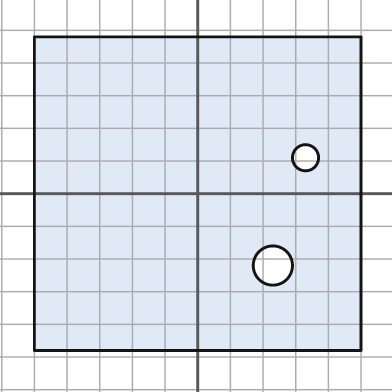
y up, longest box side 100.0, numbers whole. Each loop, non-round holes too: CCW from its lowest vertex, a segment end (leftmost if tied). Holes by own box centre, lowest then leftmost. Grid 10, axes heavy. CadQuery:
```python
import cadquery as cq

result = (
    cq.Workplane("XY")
    .moveTo(-50.0, -48.0)
    .lineTo(50.0, -48.0)
    .lineTo(50.0, 48.0)
    .lineTo(-50.0, 48.0)
    .close()
    .moveTo(23.0, -22.0)
    .circle(6.0)
    .moveTo(33.0, 11.0)
    .circle(4.0)
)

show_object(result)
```